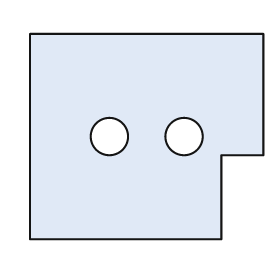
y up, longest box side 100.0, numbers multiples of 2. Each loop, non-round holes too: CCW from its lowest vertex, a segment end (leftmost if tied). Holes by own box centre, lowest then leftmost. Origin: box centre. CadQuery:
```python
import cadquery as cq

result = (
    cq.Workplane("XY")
    .moveTo(-50.0, -44.0)
    .lineTo(32.0, -44.0)
    .lineTo(32.0, -8.0)
    .lineTo(50.0, -8.0)
    .lineTo(50.0, 44.0)
    .lineTo(-50.0, 44.0)
    .close()
    .moveTo(-16.0, 0.0)
    .circle(8.0)
    .moveTo(16.0, 0.0)
    .circle(8.0)
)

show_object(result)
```